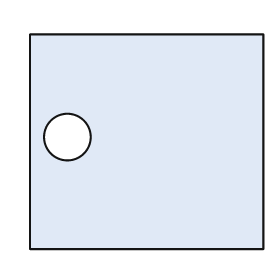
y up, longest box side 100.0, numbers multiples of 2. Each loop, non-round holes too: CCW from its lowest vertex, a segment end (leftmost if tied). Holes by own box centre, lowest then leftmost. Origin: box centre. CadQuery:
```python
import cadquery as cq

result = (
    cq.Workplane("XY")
    .moveTo(-50.0, -46.0)
    .lineTo(50.0, -46.0)
    .lineTo(50.0, 46.0)
    .lineTo(-50.0, 46.0)
    .close()
    .moveTo(-34.0, 2.0)
    .circle(10.0)
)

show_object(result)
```